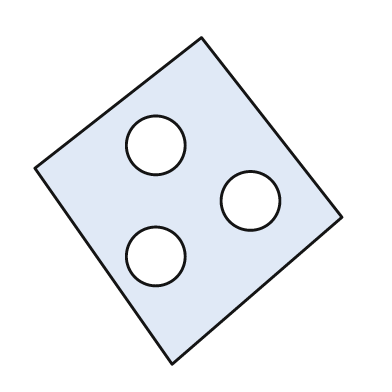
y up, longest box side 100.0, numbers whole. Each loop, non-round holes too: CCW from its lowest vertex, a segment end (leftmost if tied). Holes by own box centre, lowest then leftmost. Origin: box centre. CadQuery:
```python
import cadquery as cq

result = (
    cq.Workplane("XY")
    .moveTo(-5.0, -50.0)
    .lineTo(47.0, -5.0)
    .lineTo(4.0, 50.0)
    .lineTo(-47.0, 10.0)
    .close()
    .moveTo(-10.0, -17.0)
    .circle(9.0)
    .moveTo(19.0, 0.0)
    .circle(9.0)
    .moveTo(-10.0, 17.0)
    .circle(9.0)
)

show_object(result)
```